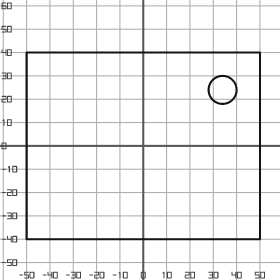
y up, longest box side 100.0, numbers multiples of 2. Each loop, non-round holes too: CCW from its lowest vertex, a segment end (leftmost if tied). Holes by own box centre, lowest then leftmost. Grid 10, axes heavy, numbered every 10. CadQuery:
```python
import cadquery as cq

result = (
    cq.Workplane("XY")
    .moveTo(-50.0, -40.0)
    .lineTo(50.0, -40.0)
    .lineTo(50.0, 40.0)
    .lineTo(-50.0, 40.0)
    .close()
    .moveTo(34.0, 24.0)
    .circle(6.0)
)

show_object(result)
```